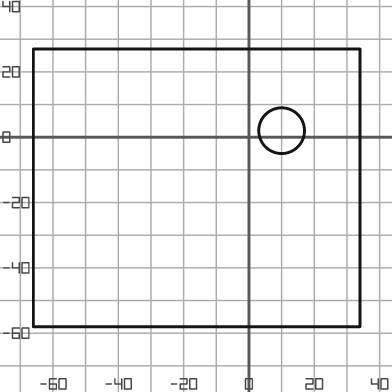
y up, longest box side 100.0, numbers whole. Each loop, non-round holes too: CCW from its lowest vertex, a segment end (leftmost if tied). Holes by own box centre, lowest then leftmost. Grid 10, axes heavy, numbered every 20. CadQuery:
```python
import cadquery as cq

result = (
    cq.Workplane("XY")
    .moveTo(-66.0, -58.0)
    .lineTo(34.0, -58.0)
    .lineTo(34.0, 27.0)
    .lineTo(-66.0, 27.0)
    .close()
    .moveTo(10.0, 2.0)
    .circle(7.0)
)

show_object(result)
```